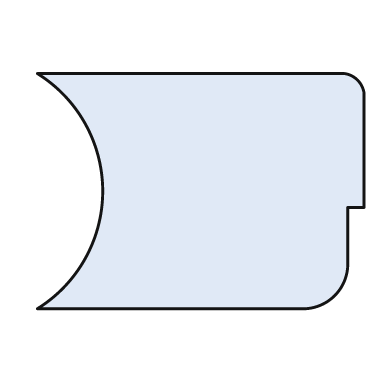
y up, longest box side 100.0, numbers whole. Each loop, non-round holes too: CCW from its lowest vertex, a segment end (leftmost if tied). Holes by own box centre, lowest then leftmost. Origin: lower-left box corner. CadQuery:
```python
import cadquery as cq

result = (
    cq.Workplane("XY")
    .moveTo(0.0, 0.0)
    .lineTo(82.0, 0.0)
    .threePointArc((91.0, 4.0), (95.0, 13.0))
    .lineTo(95.0, 31.0)
    .lineTo(100.0, 31.0)
    .lineTo(100.0, 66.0)
    .threePointArc((98.0, 70.0), (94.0, 72.0))
    .lineTo(0.0, 72.0)
    .threePointArc((20.0, 36.0), (0.0, 0.0))
    .close()
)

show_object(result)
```